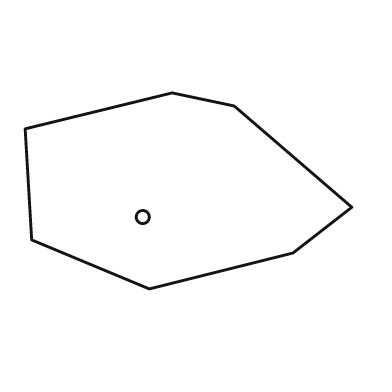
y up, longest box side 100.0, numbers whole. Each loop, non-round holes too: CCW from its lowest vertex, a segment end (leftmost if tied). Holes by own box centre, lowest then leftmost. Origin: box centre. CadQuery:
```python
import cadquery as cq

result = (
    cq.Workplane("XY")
    .moveTo(-12.0, -30.0)
    .lineTo(32.0, -19.0)
    .lineTo(50.0, -5.0)
    .lineTo(14.0, 26.0)
    .lineTo(-5.0, 30.0)
    .lineTo(-50.0, 19.0)
    .lineTo(-48.0, -15.0)
    .close()
    .moveTo(-14.0, -8.0)
    .circle(2.0)
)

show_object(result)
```